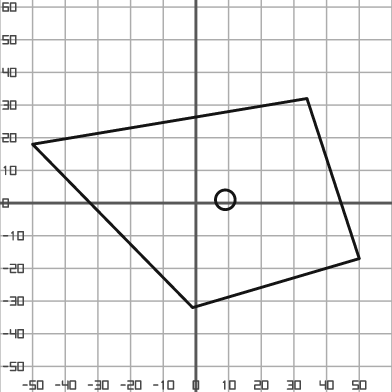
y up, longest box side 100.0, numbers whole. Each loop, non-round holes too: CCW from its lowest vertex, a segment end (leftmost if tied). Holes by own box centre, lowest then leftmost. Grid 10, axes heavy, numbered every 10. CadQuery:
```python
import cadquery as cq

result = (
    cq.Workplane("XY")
    .moveTo(-1.0, -32.0)
    .lineTo(50.0, -17.0)
    .lineTo(34.0, 32.0)
    .lineTo(-50.0, 18.0)
    .close()
    .moveTo(9.0, 1.0)
    .circle(3.0)
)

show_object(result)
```